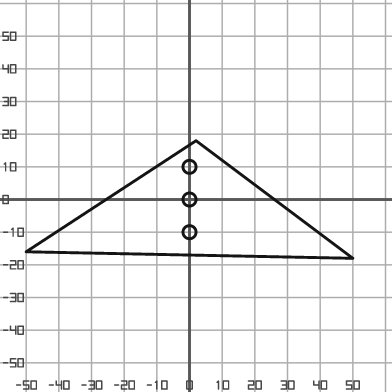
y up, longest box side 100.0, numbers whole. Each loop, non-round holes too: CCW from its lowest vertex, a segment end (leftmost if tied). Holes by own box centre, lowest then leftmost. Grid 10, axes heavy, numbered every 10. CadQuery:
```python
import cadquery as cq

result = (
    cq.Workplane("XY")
    .moveTo(50.0, -18.0)
    .lineTo(2.0, 18.0)
    .lineTo(-50.0, -16.0)
    .close()
    .moveTo(0.0, -10.0)
    .circle(2.0)
    .moveTo(0.0, 0.0)
    .circle(2.0)
    .moveTo(0.0, 10.0)
    .circle(2.0)
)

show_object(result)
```